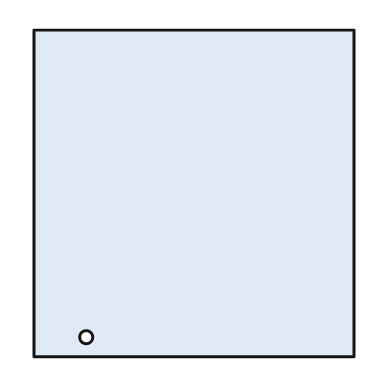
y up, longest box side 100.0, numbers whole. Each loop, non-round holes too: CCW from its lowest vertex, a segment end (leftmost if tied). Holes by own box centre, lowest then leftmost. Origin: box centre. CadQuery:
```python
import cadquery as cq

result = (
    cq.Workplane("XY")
    .moveTo(-49.0, -50.0)
    .lineTo(49.0, -50.0)
    .lineTo(49.0, 50.0)
    .lineTo(-49.0, 50.0)
    .close()
    .moveTo(-33.0, -44.0)
    .circle(2.0)
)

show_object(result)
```